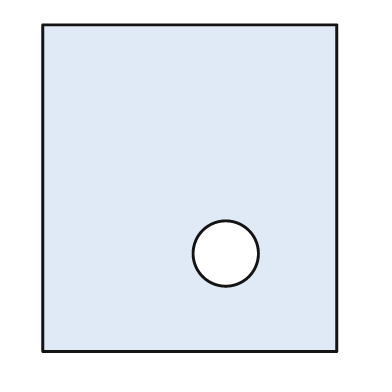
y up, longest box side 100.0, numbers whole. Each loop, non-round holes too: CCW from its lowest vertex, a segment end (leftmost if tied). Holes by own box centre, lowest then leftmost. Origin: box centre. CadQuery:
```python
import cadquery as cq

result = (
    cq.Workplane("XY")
    .moveTo(-45.0, -50.0)
    .lineTo(45.0, -50.0)
    .lineTo(45.0, 50.0)
    .lineTo(-45.0, 50.0)
    .close()
    .moveTo(11.0, -20.0)
    .circle(10.0)
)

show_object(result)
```